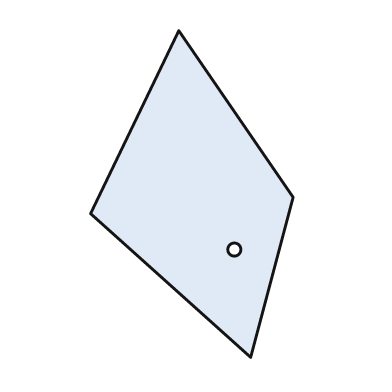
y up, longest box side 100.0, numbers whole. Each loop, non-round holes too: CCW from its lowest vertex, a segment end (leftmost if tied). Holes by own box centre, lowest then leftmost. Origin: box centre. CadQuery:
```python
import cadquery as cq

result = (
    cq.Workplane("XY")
    .moveTo(18.0, -50.0)
    .lineTo(31.0, -1.0)
    .lineTo(-4.0, 50.0)
    .lineTo(-31.0, -6.0)
    .close()
    .moveTo(13.0, -17.0)
    .circle(2.0)
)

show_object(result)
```